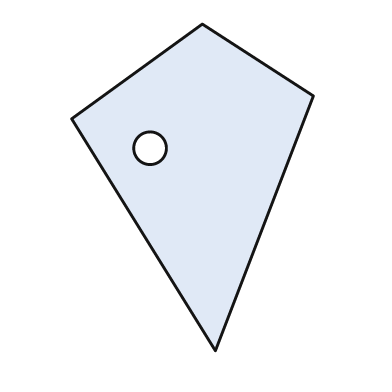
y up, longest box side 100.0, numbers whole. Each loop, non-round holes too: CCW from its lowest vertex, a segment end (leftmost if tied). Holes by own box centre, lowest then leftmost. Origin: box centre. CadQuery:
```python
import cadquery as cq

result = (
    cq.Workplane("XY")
    .moveTo(7.0, -50.0)
    .lineTo(37.0, 28.0)
    .lineTo(3.0, 50.0)
    .lineTo(-37.0, 21.0)
    .close()
    .moveTo(-13.0, 12.0)
    .circle(5.0)
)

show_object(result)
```